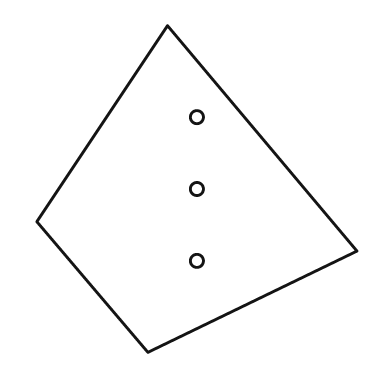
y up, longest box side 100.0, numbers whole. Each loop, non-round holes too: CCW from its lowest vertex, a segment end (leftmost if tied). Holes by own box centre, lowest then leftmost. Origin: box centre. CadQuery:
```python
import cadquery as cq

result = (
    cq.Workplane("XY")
    .moveTo(-15.0, -50.0)
    .lineTo(49.0, -19.0)
    .lineTo(-9.0, 50.0)
    .lineTo(-49.0, -10.0)
    .close()
    .moveTo(0.0, -22.0)
    .circle(2.0)
    .moveTo(0.0, 0.0)
    .circle(2.0)
    .moveTo(0.0, 22.0)
    .circle(2.0)
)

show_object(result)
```